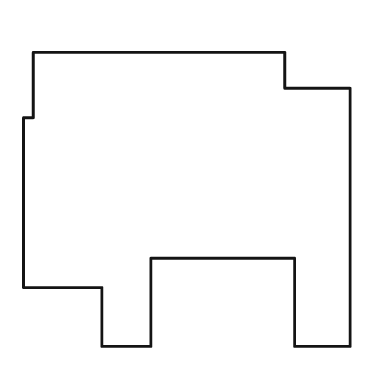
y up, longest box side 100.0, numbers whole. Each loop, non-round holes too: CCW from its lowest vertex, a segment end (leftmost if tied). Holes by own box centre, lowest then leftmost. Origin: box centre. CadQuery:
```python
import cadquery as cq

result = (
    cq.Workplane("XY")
    .moveTo(-26.0, -45.0)
    .lineTo(-11.0, -45.0)
    .lineTo(-11.0, -18.0)
    .lineTo(33.0, -18.0)
    .lineTo(33.0, -45.0)
    .lineTo(50.0, -45.0)
    .lineTo(50.0, 34.0)
    .lineTo(30.0, 34.0)
    .lineTo(30.0, 45.0)
    .lineTo(-47.0, 45.0)
    .lineTo(-47.0, 25.0)
    .lineTo(-50.0, 25.0)
    .lineTo(-50.0, -27.0)
    .lineTo(-26.0, -27.0)
    .close()
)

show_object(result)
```